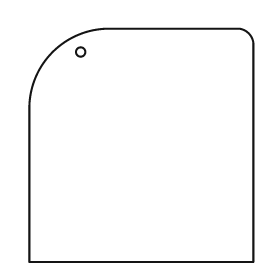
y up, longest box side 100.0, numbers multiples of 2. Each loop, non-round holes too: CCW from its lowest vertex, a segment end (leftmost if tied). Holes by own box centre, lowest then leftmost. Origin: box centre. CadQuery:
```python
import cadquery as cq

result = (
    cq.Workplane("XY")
    .moveTo(-48.0, -50.0)
    .lineTo(48.0, -50.0)
    .lineTo(48.0, 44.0)
    .threePointArc((46.0, 48.0), (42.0, 50.0))
    .lineTo(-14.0, 50.0)
    .threePointArc((-38.0, 40.0), (-48.0, 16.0))
    .close()
    .moveTo(-26.0, 40.0)
    .circle(2.0)
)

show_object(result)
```